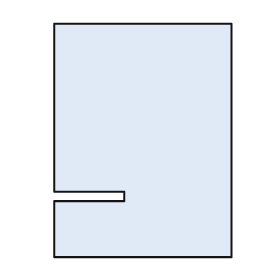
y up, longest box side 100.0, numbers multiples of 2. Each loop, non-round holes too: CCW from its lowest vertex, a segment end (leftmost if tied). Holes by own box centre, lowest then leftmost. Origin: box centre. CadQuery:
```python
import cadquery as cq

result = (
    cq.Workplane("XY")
    .moveTo(-38.0, -50.0)
    .lineTo(38.0, -50.0)
    .lineTo(38.0, 50.0)
    .lineTo(-38.0, 50.0)
    .lineTo(-38.0, -22.0)
    .lineTo(-8.0, -22.0)
    .lineTo(-8.0, -26.0)
    .lineTo(-38.0, -26.0)
    .close()
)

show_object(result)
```